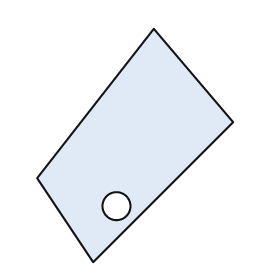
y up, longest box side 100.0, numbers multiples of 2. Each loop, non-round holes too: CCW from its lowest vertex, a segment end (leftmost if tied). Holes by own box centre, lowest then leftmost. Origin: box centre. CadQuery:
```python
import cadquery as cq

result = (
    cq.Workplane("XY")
    .moveTo(-18.0, -50.0)
    .lineTo(42.0, 10.0)
    .lineTo(8.0, 50.0)
    .lineTo(-42.0, -14.0)
    .close()
    .moveTo(-8.0, -26.0)
    .circle(6.0)
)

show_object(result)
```